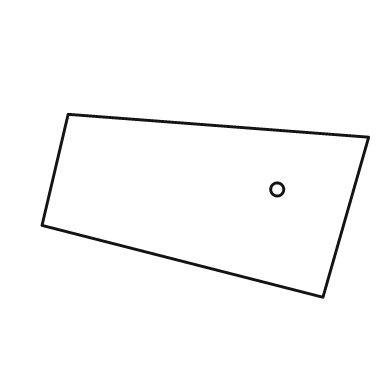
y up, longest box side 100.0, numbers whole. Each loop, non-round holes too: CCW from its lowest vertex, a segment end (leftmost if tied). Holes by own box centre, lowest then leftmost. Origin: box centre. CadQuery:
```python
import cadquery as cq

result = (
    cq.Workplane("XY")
    .moveTo(36.0, -28.0)
    .lineTo(50.0, 21.0)
    .lineTo(-42.0, 28.0)
    .lineTo(-50.0, -6.0)
    .close()
    .moveTo(22.0, 5.0)
    .circle(2.0)
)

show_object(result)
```